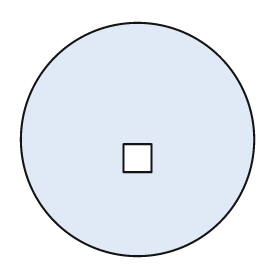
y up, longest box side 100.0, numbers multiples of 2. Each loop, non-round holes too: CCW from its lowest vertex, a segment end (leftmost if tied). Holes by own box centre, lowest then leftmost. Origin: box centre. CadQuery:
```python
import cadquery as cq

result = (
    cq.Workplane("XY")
    .moveTo(0.0, 0.0)
    .circle(50.0)
    .moveTo(-6.0, -14.0)
    .lineTo(6.0, -14.0)
    .lineTo(6.0, -2.0)
    .lineTo(-6.0, -2.0)
    .close()
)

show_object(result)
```